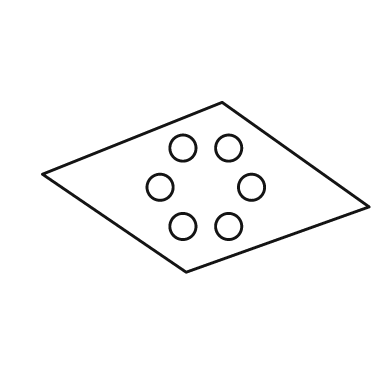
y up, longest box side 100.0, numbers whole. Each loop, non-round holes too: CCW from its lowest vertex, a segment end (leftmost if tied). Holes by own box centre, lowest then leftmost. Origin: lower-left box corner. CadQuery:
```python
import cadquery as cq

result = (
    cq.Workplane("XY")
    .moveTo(44.0, 0.0)
    .lineTo(100.0, 20.0)
    .lineTo(55.0, 52.0)
    .lineTo(0.0, 30.0)
    .close()
    .moveTo(43.0, 14.0)
    .circle(4.0)
    .moveTo(57.0, 14.0)
    .circle(4.0)
    .moveTo(36.0, 26.0)
    .circle(4.0)
    .moveTo(64.0, 26.0)
    .circle(4.0)
    .moveTo(43.0, 38.0)
    .circle(4.0)
    .moveTo(57.0, 38.0)
    .circle(4.0)
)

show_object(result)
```